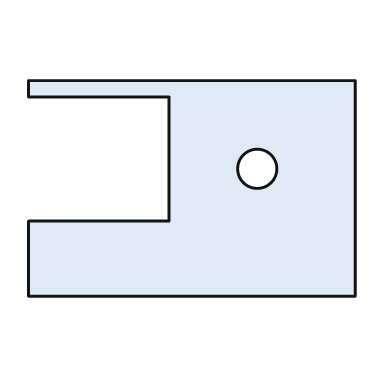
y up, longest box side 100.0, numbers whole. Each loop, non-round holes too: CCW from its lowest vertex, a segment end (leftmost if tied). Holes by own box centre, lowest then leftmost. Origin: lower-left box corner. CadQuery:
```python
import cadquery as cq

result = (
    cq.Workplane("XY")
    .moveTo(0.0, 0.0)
    .lineTo(100.0, 0.0)
    .lineTo(100.0, 66.0)
    .lineTo(0.0, 66.0)
    .lineTo(0.0, 61.0)
    .lineTo(43.0, 61.0)
    .lineTo(43.0, 23.0)
    .lineTo(0.0, 23.0)
    .close()
    .moveTo(70.0, 39.0)
    .circle(6.0)
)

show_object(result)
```